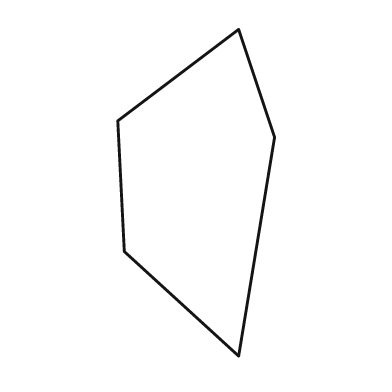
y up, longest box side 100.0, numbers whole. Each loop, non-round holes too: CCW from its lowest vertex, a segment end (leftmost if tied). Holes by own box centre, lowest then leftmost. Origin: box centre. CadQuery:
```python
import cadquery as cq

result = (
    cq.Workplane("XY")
    .moveTo(13.0, -50.0)
    .lineTo(24.0, 17.0)
    .lineTo(13.0, 50.0)
    .lineTo(-24.0, 22.0)
    .lineTo(-22.0, -18.0)
    .close()
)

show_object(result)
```